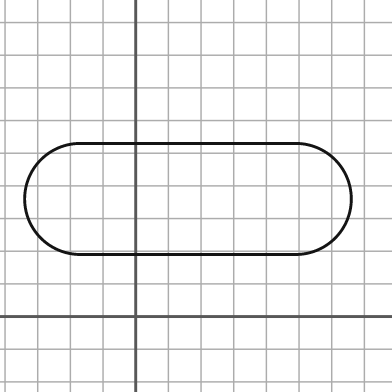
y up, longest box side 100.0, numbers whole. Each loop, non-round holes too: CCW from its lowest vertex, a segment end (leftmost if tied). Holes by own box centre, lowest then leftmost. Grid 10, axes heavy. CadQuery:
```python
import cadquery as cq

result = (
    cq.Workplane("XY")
    .moveTo(-17.0, 19.0)
    .lineTo(49.0, 19.0)
    .threePointArc((66.0, 36.0), (49.0, 53.0))
    .lineTo(-17.0, 53.0)
    .threePointArc((-34.0, 36.0), (-17.0, 19.0))
    .close()
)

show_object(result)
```